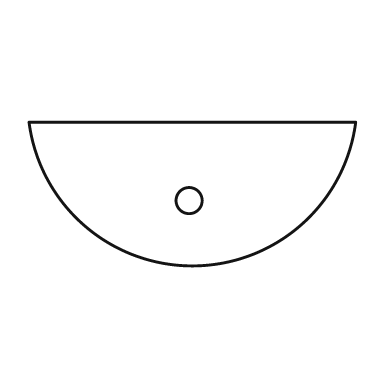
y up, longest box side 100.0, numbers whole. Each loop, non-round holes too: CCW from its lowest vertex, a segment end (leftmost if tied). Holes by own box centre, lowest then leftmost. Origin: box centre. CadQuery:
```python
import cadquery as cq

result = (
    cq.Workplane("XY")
    .moveTo(-50.0, 22.0)
    .threePointArc((0.0, -22.0), (50.0, 22.0))
    .close()
    .moveTo(-1.0, -2.0)
    .circle(4.0)
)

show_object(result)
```